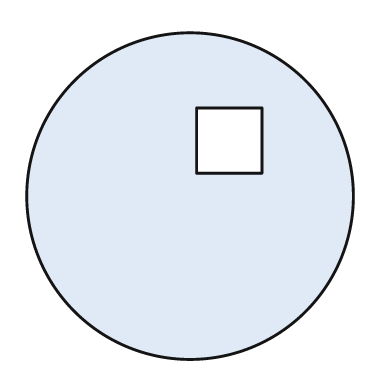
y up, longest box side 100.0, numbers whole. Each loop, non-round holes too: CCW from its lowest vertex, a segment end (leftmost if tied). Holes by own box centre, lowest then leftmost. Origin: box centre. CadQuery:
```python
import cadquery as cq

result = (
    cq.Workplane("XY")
    .moveTo(0.0, 0.0)
    .circle(50.0)
    .moveTo(2.0, 7.0)
    .lineTo(22.0, 7.0)
    .lineTo(22.0, 27.0)
    .lineTo(2.0, 27.0)
    .close()
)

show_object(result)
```